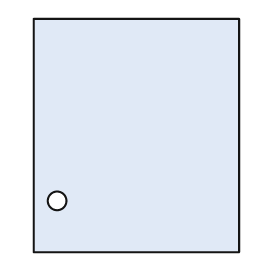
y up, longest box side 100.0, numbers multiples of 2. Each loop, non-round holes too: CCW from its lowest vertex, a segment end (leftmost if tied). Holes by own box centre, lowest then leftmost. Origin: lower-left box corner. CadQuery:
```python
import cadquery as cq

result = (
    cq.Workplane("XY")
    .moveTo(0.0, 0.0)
    .lineTo(88.0, 0.0)
    .lineTo(88.0, 100.0)
    .lineTo(0.0, 100.0)
    .close()
    .moveTo(10.0, 22.0)
    .circle(4.0)
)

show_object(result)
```